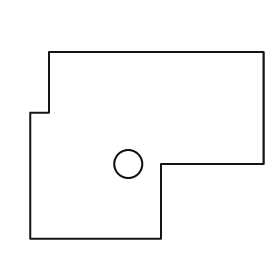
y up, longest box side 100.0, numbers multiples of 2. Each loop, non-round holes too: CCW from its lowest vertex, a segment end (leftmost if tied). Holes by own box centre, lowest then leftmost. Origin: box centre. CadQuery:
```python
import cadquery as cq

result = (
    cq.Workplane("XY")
    .moveTo(-50.0, -40.0)
    .lineTo(6.0, -40.0)
    .lineTo(6.0, -8.0)
    .lineTo(50.0, -8.0)
    .lineTo(50.0, 40.0)
    .lineTo(-42.0, 40.0)
    .lineTo(-42.0, 14.0)
    .lineTo(-50.0, 14.0)
    .close()
    .moveTo(-8.0, -8.0)
    .circle(6.0)
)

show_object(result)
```